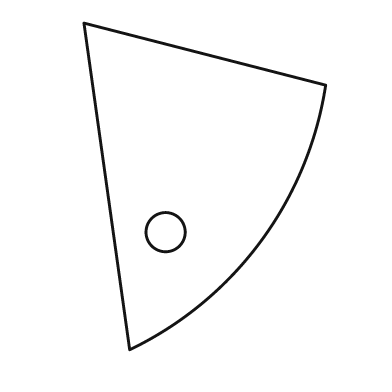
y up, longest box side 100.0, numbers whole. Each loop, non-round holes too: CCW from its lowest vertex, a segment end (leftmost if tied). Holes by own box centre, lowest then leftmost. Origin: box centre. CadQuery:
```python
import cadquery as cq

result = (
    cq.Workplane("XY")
    .moveTo(-23.0, -50.0)
    .threePointArc((17.0, -17.0), (37.0, 31.0))
    .lineTo(-37.0, 50.0)
    .close()
    .moveTo(-12.0, -14.0)
    .circle(6.0)
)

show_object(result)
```